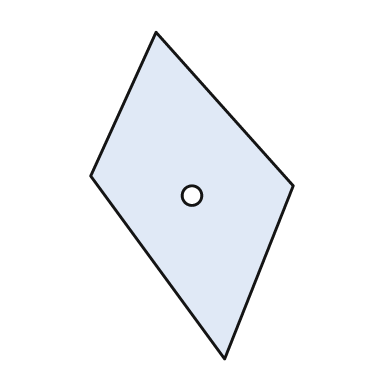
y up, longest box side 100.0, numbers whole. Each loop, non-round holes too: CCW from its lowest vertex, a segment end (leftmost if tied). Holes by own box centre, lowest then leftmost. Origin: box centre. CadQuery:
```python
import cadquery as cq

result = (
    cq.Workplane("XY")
    .moveTo(10.0, -50.0)
    .lineTo(31.0, 3.0)
    .lineTo(-11.0, 50.0)
    .lineTo(-31.0, 6.0)
    .close()
    .moveTo(0.0, 0.0)
    .circle(3.0)
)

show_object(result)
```